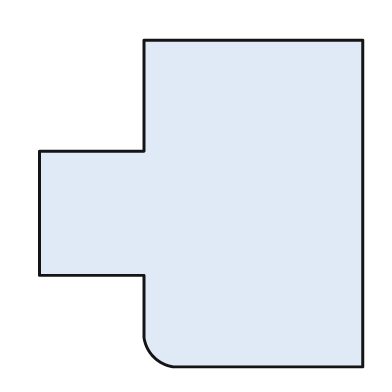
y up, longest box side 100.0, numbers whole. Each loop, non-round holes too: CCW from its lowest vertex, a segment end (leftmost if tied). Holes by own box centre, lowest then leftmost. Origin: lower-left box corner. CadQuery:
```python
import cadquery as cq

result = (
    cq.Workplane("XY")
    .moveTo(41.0, 0.0)
    .lineTo(99.0, 0.0)
    .lineTo(99.0, 100.0)
    .lineTo(32.0, 100.0)
    .lineTo(32.0, 66.0)
    .lineTo(0.0, 66.0)
    .lineTo(0.0, 28.0)
    .lineTo(32.0, 28.0)
    .lineTo(32.0, 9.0)
    .threePointArc((35.0, 3.0), (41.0, 0.0))
    .close()
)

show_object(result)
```